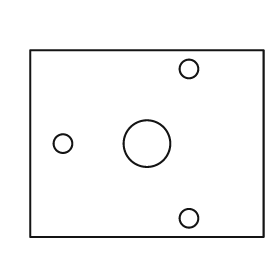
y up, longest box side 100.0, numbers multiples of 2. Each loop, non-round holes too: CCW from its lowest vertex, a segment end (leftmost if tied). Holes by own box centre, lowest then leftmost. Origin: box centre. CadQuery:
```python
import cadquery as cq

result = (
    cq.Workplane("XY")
    .moveTo(-50.0, -40.0)
    .lineTo(50.0, -40.0)
    .lineTo(50.0, 40.0)
    .lineTo(-50.0, 40.0)
    .close()
    .moveTo(18.0, -32.0)
    .circle(4.0)
    .moveTo(-36.0, 0.0)
    .circle(4.0)
    .moveTo(0.0, 0.0)
    .circle(10.0)
    .moveTo(18.0, 32.0)
    .circle(4.0)
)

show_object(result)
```